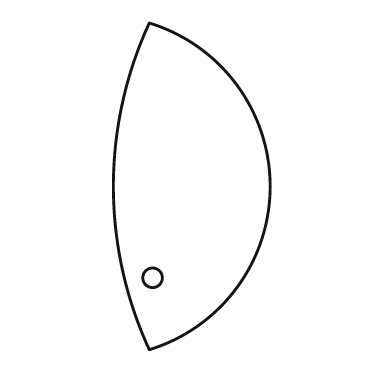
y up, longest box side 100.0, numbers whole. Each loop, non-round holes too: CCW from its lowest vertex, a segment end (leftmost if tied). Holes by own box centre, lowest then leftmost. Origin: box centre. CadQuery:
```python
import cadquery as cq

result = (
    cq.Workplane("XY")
    .moveTo(-13.0, -50.0)
    .threePointArc((24.0, 0.0), (-13.0, 50.0))
    .threePointArc((-24.0, 0.0), (-13.0, -50.0))
    .close()
    .moveTo(-12.0, -28.0)
    .circle(3.0)
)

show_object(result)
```